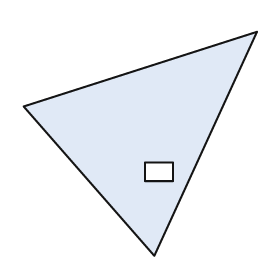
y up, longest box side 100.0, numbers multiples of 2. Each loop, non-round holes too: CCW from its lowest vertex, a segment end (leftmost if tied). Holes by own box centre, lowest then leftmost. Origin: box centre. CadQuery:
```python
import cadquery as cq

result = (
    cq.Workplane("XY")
    .moveTo(6.0, -48.0)
    .lineTo(50.0, 48.0)
    .lineTo(-50.0, 16.0)
    .close()
    .moveTo(2.0, -16.0)
    .lineTo(14.0, -16.0)
    .lineTo(14.0, -8.0)
    .lineTo(2.0, -8.0)
    .close()
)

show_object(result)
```